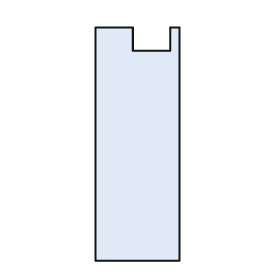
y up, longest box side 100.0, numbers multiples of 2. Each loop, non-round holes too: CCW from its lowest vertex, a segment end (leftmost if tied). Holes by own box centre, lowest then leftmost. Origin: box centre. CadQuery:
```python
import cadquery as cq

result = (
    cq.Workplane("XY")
    .moveTo(-18.0, -50.0)
    .lineTo(18.0, -50.0)
    .lineTo(18.0, 50.0)
    .lineTo(14.0, 50.0)
    .lineTo(14.0, 40.0)
    .lineTo(-2.0, 40.0)
    .lineTo(-2.0, 50.0)
    .lineTo(-18.0, 50.0)
    .close()
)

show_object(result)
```